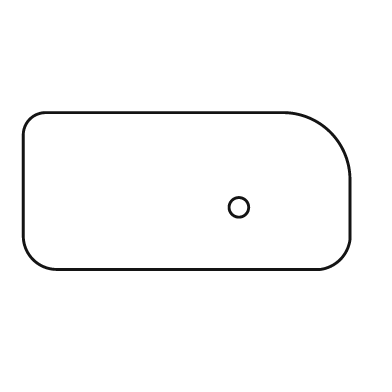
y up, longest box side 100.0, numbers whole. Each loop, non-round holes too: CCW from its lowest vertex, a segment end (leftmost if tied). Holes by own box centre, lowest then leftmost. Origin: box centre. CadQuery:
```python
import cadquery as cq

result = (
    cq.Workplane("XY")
    .moveTo(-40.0, -24.0)
    .lineTo(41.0, -24.0)
    .threePointArc((47.0, -21.0), (50.0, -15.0))
    .lineTo(50.0, 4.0)
    .threePointArc((44.0, 18.0), (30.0, 24.0))
    .lineTo(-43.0, 24.0)
    .threePointArc((-48.0, 22.0), (-50.0, 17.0))
    .lineTo(-50.0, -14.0)
    .threePointArc((-47.0, -21.0), (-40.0, -24.0))
    .close()
    .moveTo(16.0, -5.0)
    .circle(3.0)
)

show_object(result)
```